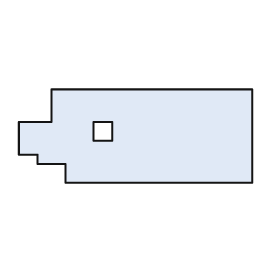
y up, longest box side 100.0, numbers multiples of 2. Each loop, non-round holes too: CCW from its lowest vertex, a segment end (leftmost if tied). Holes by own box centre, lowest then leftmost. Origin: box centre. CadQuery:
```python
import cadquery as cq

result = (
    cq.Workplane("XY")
    .moveTo(-30.0, -20.0)
    .lineTo(50.0, -20.0)
    .lineTo(50.0, 20.0)
    .lineTo(-36.0, 20.0)
    .lineTo(-36.0, 6.0)
    .lineTo(-50.0, 6.0)
    .lineTo(-50.0, -8.0)
    .lineTo(-42.0, -8.0)
    .lineTo(-42.0, -12.0)
    .lineTo(-30.0, -12.0)
    .close()
    .moveTo(-18.0, -2.0)
    .lineTo(-10.0, -2.0)
    .lineTo(-10.0, 6.0)
    .lineTo(-18.0, 6.0)
    .close()
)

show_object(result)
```